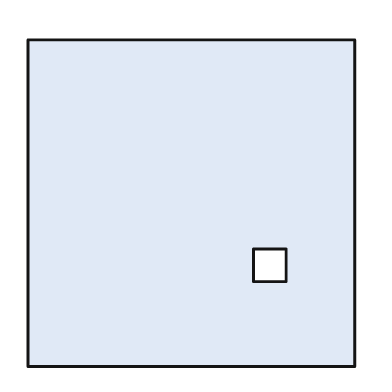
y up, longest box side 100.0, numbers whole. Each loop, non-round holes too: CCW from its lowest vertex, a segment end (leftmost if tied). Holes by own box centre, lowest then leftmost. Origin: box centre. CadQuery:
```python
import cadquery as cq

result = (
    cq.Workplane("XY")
    .moveTo(-50.0, -50.0)
    .lineTo(50.0, -50.0)
    .lineTo(50.0, 50.0)
    .lineTo(-50.0, 50.0)
    .close()
    .moveTo(19.0, -24.0)
    .lineTo(29.0, -24.0)
    .lineTo(29.0, -14.0)
    .lineTo(19.0, -14.0)
    .close()
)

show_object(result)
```